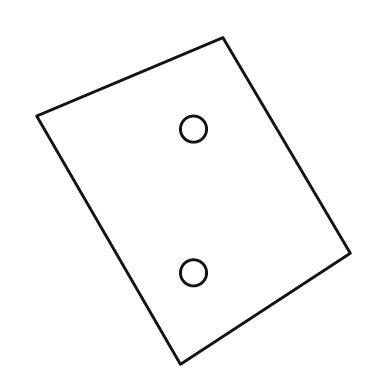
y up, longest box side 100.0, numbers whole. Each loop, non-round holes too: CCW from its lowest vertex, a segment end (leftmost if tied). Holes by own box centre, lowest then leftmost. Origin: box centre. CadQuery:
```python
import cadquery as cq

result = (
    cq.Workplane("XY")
    .moveTo(-4.0, -50.0)
    .lineTo(48.0, -16.0)
    .lineTo(9.0, 50.0)
    .lineTo(-48.0, 26.0)
    .close()
    .moveTo(0.0, -22.0)
    .circle(4.0)
    .moveTo(0.0, 22.0)
    .circle(4.0)
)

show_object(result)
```